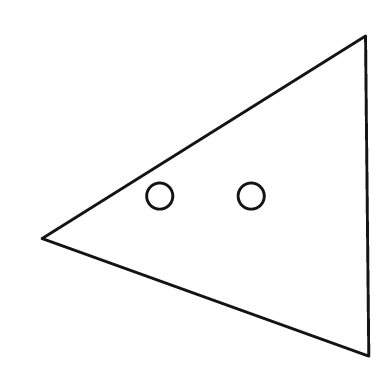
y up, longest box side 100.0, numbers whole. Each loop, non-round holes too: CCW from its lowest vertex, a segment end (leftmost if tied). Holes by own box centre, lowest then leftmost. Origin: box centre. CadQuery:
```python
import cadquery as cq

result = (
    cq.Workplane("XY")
    .moveTo(50.0, -49.0)
    .lineTo(49.0, 49.0)
    .lineTo(-50.0, -13.0)
    .close()
    .moveTo(-14.0, 0.0)
    .circle(4.0)
    .moveTo(14.0, 0.0)
    .circle(4.0)
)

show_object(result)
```